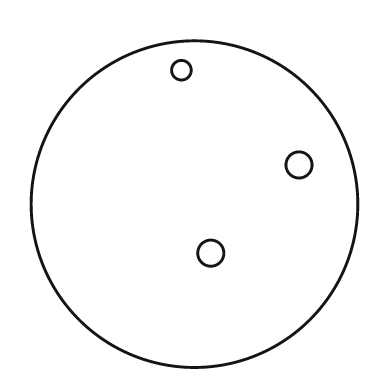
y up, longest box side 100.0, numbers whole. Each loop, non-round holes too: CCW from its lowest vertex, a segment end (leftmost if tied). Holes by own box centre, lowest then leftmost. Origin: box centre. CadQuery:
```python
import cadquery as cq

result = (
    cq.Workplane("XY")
    .moveTo(0.0, 0.0)
    .circle(50.0)
    .moveTo(5.0, -15.0)
    .circle(4.0)
    .moveTo(32.0, 12.0)
    .circle(4.0)
    .moveTo(-4.0, 41.0)
    .circle(3.0)
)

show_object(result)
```